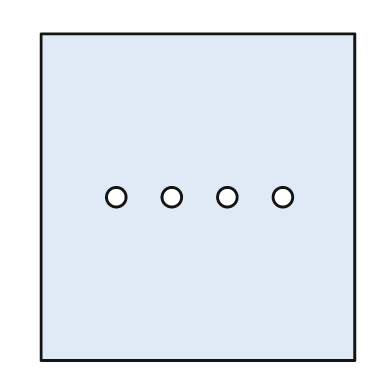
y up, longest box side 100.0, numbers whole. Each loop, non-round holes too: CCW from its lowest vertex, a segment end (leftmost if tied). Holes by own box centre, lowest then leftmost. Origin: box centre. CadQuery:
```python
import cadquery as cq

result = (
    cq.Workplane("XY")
    .moveTo(-48.0, -50.0)
    .lineTo(48.0, -50.0)
    .lineTo(48.0, 50.0)
    .lineTo(-48.0, 50.0)
    .close()
    .moveTo(-25.0, 0.0)
    .circle(3.0)
    .moveTo(-8.0, 0.0)
    .circle(3.0)
    .moveTo(9.0, 0.0)
    .circle(3.0)
    .moveTo(26.0, 0.0)
    .circle(3.0)
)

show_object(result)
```